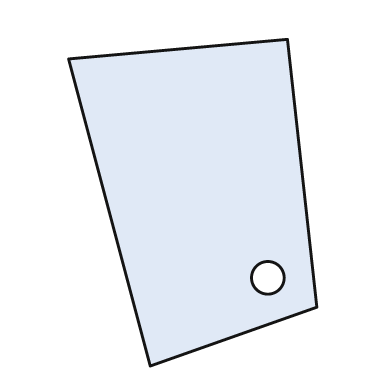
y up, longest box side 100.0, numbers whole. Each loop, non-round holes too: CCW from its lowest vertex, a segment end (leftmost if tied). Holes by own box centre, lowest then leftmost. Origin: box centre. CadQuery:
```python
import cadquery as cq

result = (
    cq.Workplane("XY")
    .moveTo(-13.0, -50.0)
    .lineTo(38.0, -32.0)
    .lineTo(29.0, 50.0)
    .lineTo(-38.0, 44.0)
    .close()
    .moveTo(23.0, -23.0)
    .circle(5.0)
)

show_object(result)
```